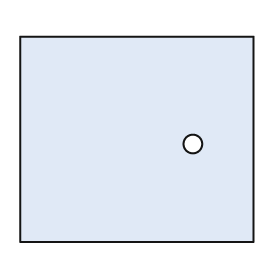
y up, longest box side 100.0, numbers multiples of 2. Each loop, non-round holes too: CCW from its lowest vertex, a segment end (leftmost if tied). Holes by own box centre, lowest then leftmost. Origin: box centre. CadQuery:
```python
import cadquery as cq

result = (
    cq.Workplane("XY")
    .moveTo(-50.0, -44.0)
    .lineTo(50.0, -44.0)
    .lineTo(50.0, 44.0)
    .lineTo(-50.0, 44.0)
    .close()
    .moveTo(24.0, -2.0)
    .circle(4.0)
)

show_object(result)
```